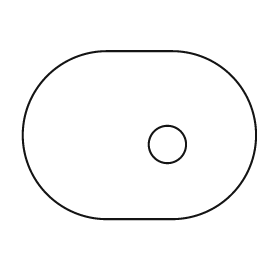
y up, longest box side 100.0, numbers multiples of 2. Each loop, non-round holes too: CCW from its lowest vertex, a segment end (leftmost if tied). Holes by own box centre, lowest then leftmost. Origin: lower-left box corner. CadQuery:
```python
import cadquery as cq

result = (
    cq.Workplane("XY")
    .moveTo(36.0, 0.0)
    .lineTo(64.0, 0.0)
    .threePointArc((100.0, 36.0), (64.0, 72.0))
    .lineTo(36.0, 72.0)
    .threePointArc((0.0, 36.0), (36.0, 0.0))
    .close()
    .moveTo(62.0, 32.0)
    .circle(8.0)
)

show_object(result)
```